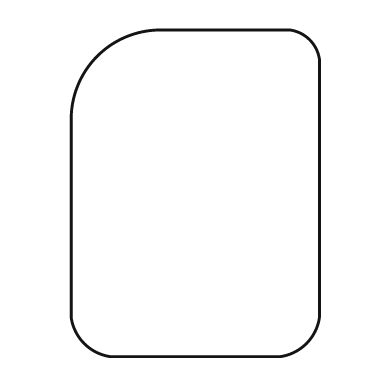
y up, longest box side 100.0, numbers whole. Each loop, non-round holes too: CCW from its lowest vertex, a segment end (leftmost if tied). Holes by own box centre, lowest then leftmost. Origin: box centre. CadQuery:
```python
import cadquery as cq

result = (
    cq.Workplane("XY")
    .moveTo(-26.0, -50.0)
    .lineTo(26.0, -50.0)
    .threePointArc((34.0, -46.0), (38.0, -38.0))
    .lineTo(38.0, 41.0)
    .threePointArc((35.0, 47.0), (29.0, 50.0))
    .lineTo(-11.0, 50.0)
    .threePointArc((-30.0, 42.0), (-38.0, 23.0))
    .lineTo(-38.0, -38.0)
    .threePointArc((-34.0, -46.0), (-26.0, -50.0))
    .close()
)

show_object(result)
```